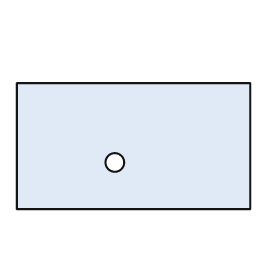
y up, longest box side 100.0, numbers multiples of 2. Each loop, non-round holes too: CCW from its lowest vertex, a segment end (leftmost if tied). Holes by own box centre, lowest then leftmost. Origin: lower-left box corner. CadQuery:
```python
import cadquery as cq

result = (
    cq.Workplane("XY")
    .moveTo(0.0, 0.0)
    .lineTo(100.0, 0.0)
    .lineTo(100.0, 54.0)
    .lineTo(0.0, 54.0)
    .close()
    .moveTo(42.0, 20.0)
    .circle(4.0)
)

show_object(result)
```